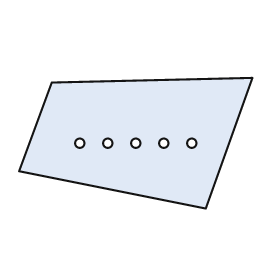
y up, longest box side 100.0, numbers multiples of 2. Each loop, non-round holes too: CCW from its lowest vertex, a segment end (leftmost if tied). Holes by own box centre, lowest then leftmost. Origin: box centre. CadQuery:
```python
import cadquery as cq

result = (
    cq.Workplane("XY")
    .moveTo(30.0, -28.0)
    .lineTo(50.0, 28.0)
    .lineTo(-36.0, 26.0)
    .lineTo(-50.0, -12.0)
    .close()
    .moveTo(-24.0, 0.0)
    .circle(2.0)
    .moveTo(-12.0, 0.0)
    .circle(2.0)
    .moveTo(0.0, 0.0)
    .circle(2.0)
    .moveTo(12.0, 0.0)
    .circle(2.0)
    .moveTo(24.0, 0.0)
    .circle(2.0)
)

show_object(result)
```